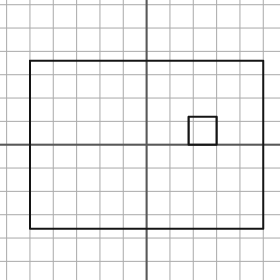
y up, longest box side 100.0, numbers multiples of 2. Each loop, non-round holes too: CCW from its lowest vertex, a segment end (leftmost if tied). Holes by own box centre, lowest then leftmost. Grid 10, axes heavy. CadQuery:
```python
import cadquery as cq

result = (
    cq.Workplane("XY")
    .moveTo(-50.0, -36.0)
    .lineTo(50.0, -36.0)
    .lineTo(50.0, 36.0)
    .lineTo(-50.0, 36.0)
    .close()
    .moveTo(18.0, 0.0)
    .lineTo(30.0, 0.0)
    .lineTo(30.0, 12.0)
    .lineTo(18.0, 12.0)
    .close()
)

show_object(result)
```